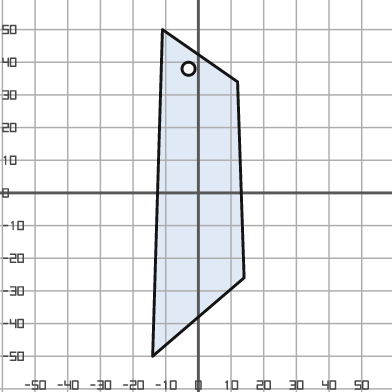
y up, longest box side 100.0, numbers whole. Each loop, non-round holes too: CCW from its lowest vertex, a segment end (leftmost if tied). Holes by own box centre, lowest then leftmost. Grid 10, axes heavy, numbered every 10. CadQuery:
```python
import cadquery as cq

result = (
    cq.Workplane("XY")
    .moveTo(-14.0, -50.0)
    .lineTo(14.0, -26.0)
    .lineTo(12.0, 34.0)
    .lineTo(-11.0, 50.0)
    .close()
    .moveTo(-3.0, 38.0)
    .circle(2.0)
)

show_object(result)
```